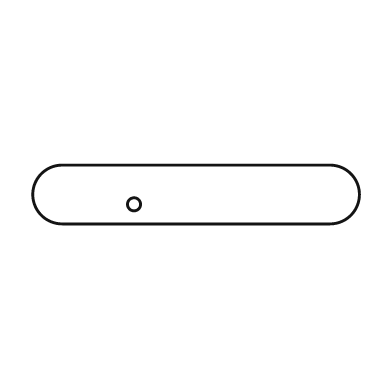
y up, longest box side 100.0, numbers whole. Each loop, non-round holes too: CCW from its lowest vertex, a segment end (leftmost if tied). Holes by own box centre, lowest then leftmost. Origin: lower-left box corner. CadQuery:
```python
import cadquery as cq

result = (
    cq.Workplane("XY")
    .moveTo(9.0, 0.0)
    .lineTo(91.0, 0.0)
    .threePointArc((100.0, 9.0), (91.0, 18.0))
    .lineTo(9.0, 18.0)
    .threePointArc((0.0, 9.0), (9.0, 0.0))
    .close()
    .moveTo(31.0, 6.0)
    .circle(2.0)
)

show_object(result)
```